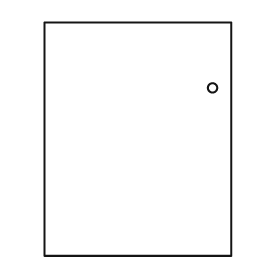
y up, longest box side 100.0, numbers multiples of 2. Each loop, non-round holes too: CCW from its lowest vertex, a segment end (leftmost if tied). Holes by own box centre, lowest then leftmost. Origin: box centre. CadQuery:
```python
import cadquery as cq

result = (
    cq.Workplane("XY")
    .moveTo(-40.0, -50.0)
    .lineTo(40.0, -50.0)
    .lineTo(40.0, 50.0)
    .lineTo(-40.0, 50.0)
    .close()
    .moveTo(32.0, 22.0)
    .circle(2.0)
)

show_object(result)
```